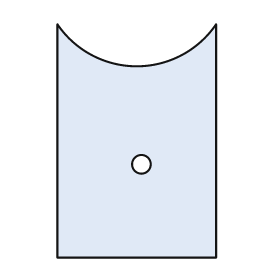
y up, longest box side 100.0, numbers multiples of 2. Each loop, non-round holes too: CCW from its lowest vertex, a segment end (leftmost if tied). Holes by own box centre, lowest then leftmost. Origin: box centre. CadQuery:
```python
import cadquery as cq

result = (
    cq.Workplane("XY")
    .moveTo(-34.0, -50.0)
    .lineTo(34.0, -50.0)
    .lineTo(34.0, 50.0)
    .threePointArc((0.0, 32.0), (-34.0, 50.0))
    .close()
    .moveTo(2.0, -10.0)
    .circle(4.0)
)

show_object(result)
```